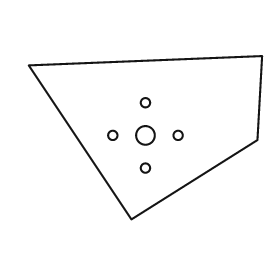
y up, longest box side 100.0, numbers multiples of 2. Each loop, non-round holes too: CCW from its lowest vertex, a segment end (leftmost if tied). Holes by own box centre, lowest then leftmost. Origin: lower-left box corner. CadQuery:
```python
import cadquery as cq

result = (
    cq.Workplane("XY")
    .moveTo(44.0, 0.0)
    .lineTo(98.0, 34.0)
    .lineTo(100.0, 70.0)
    .lineTo(0.0, 66.0)
    .close()
    .moveTo(50.0, 22.0)
    .circle(2.0)
    .moveTo(36.0, 36.0)
    .circle(2.0)
    .moveTo(50.0, 36.0)
    .circle(4.0)
    .moveTo(64.0, 36.0)
    .circle(2.0)
    .moveTo(50.0, 50.0)
    .circle(2.0)
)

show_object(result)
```